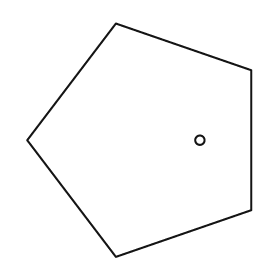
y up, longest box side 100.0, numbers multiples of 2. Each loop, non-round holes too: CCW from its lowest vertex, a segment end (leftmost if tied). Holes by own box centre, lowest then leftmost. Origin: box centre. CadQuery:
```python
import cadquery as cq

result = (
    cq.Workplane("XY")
    .moveTo(-10.0, -50.0)
    .lineTo(48.0, -30.0)
    .lineTo(48.0, 30.0)
    .lineTo(-10.0, 50.0)
    .lineTo(-48.0, 0.0)
    .close()
    .moveTo(26.0, 0.0)
    .circle(2.0)
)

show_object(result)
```